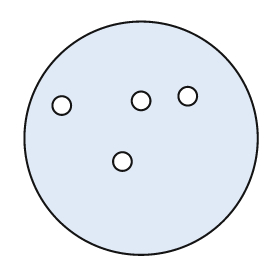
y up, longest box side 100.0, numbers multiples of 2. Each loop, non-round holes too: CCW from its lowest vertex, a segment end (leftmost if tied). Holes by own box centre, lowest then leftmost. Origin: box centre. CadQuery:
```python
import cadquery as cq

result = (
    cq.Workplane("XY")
    .moveTo(0.0, 0.0)
    .circle(50.0)
    .moveTo(-8.0, -10.0)
    .circle(4.0)
    .moveTo(-34.0, 14.0)
    .circle(4.0)
    .moveTo(0.0, 16.0)
    .circle(4.0)
    .moveTo(20.0, 18.0)
    .circle(4.0)
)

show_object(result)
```